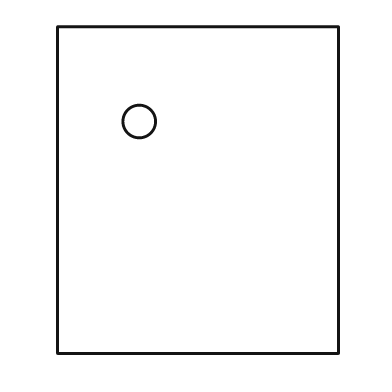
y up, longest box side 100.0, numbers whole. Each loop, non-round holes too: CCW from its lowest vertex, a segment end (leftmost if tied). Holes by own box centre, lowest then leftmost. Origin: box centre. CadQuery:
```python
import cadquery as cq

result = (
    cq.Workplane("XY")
    .moveTo(-43.0, -50.0)
    .lineTo(43.0, -50.0)
    .lineTo(43.0, 50.0)
    .lineTo(-43.0, 50.0)
    .close()
    .moveTo(-18.0, 21.0)
    .circle(5.0)
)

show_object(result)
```